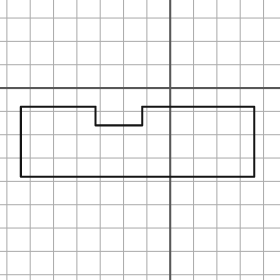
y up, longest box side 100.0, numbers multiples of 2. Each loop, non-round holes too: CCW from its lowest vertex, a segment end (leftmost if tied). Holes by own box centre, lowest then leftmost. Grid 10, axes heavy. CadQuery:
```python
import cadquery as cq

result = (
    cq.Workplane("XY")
    .moveTo(-64.0, -38.0)
    .lineTo(36.0, -38.0)
    .lineTo(36.0, -8.0)
    .lineTo(-12.0, -8.0)
    .lineTo(-12.0, -16.0)
    .lineTo(-32.0, -16.0)
    .lineTo(-32.0, -8.0)
    .lineTo(-64.0, -8.0)
    .close()
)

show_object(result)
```